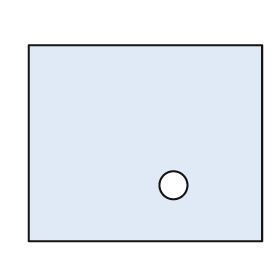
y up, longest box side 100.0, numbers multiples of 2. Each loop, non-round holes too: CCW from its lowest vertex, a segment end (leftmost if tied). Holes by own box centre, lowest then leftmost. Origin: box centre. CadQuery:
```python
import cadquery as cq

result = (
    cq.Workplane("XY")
    .moveTo(-50.0, -42.0)
    .lineTo(50.0, -42.0)
    .lineTo(50.0, 42.0)
    .lineTo(-50.0, 42.0)
    .close()
    .moveTo(12.0, -18.0)
    .circle(6.0)
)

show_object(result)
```